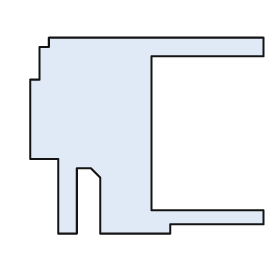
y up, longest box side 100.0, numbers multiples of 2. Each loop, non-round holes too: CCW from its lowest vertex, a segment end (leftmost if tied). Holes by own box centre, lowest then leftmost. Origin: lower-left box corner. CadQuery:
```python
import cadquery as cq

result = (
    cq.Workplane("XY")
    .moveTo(12.0, 0.0)
    .lineTo(20.0, 0.0)
    .lineTo(20.0, 28.0)
    .lineTo(26.0, 28.0)
    .lineTo(30.0, 24.0)
    .lineTo(30.0, 0.0)
    .lineTo(60.0, 0.0)
    .lineTo(60.0, 4.0)
    .lineTo(100.0, 4.0)
    .lineTo(100.0, 10.0)
    .lineTo(52.0, 10.0)
    .lineTo(52.0, 76.0)
    .lineTo(100.0, 76.0)
    .lineTo(100.0, 84.0)
    .lineTo(8.0, 84.0)
    .lineTo(8.0, 80.0)
    .lineTo(4.0, 80.0)
    .lineTo(4.0, 66.0)
    .lineTo(0.0, 66.0)
    .lineTo(0.0, 32.0)
    .lineTo(12.0, 32.0)
    .close()
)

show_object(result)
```